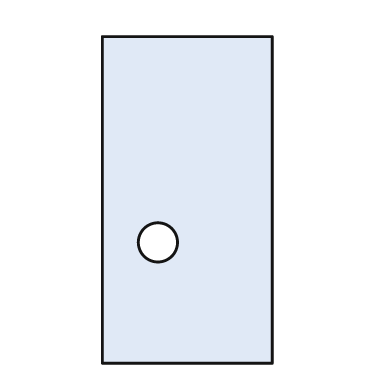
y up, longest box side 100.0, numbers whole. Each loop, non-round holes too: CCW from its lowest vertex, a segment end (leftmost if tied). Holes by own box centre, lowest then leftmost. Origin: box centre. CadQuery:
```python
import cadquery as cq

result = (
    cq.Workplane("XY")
    .moveTo(-26.0, -50.0)
    .lineTo(26.0, -50.0)
    .lineTo(26.0, 50.0)
    .lineTo(-26.0, 50.0)
    .close()
    .moveTo(-9.0, -13.0)
    .circle(6.0)
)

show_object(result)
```